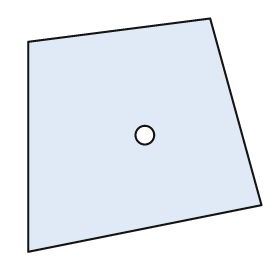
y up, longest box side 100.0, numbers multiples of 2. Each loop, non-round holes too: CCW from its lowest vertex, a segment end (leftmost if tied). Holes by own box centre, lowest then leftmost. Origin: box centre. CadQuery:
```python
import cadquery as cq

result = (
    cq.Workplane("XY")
    .moveTo(-50.0, -50.0)
    .lineTo(50.0, -30.0)
    .lineTo(28.0, 50.0)
    .lineTo(-50.0, 40.0)
    .close()
    .moveTo(0.0, 0.0)
    .circle(4.0)
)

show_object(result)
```